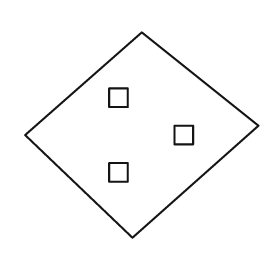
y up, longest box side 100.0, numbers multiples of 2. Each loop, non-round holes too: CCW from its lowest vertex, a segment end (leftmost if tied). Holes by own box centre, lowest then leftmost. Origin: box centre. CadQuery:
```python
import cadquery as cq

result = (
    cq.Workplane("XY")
    .moveTo(-4.0, -44.0)
    .lineTo(50.0, 4.0)
    .lineTo(0.0, 44.0)
    .lineTo(-50.0, 0.0)
    .close()
    .moveTo(-14.0, -20.0)
    .lineTo(-6.0, -20.0)
    .lineTo(-6.0, -12.0)
    .lineTo(-14.0, -12.0)
    .close()
    .moveTo(14.0, -4.0)
    .lineTo(22.0, -4.0)
    .lineTo(22.0, 4.0)
    .lineTo(14.0, 4.0)
    .close()
    .moveTo(-14.0, 12.0)
    .lineTo(-6.0, 12.0)
    .lineTo(-6.0, 20.0)
    .lineTo(-14.0, 20.0)
    .close()
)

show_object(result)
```